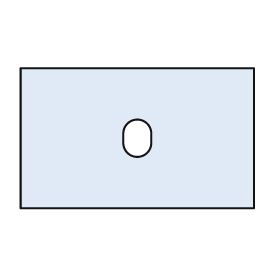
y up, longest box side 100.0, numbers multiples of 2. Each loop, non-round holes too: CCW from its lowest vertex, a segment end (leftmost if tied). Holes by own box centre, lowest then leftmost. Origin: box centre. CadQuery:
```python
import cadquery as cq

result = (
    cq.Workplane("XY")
    .moveTo(-50.0, -30.0)
    .lineTo(50.0, -30.0)
    .lineTo(50.0, 30.0)
    .lineTo(-50.0, 30.0)
    .close()
    .moveTo(-6.0, -2.0)
    .threePointArc((0.0, -8.0), (6.0, -2.0))
    .lineTo(6.0, 2.0)
    .threePointArc((0.0, 8.0), (-6.0, 2.0))
    .close()
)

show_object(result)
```